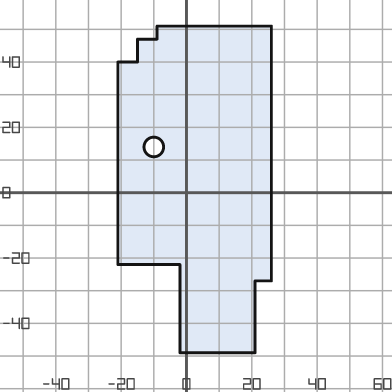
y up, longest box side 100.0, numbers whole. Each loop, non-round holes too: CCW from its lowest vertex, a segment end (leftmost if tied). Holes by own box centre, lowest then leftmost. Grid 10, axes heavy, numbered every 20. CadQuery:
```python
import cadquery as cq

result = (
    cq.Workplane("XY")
    .moveTo(-2.0, -49.0)
    .lineTo(21.0, -49.0)
    .lineTo(21.0, -27.0)
    .lineTo(26.0, -27.0)
    .lineTo(26.0, 51.0)
    .lineTo(-9.0, 51.0)
    .lineTo(-9.0, 47.0)
    .lineTo(-15.0, 47.0)
    .lineTo(-15.0, 40.0)
    .lineTo(-21.0, 40.0)
    .lineTo(-21.0, -22.0)
    .lineTo(-2.0, -22.0)
    .close()
    .moveTo(-10.0, 14.0)
    .circle(3.0)
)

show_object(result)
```